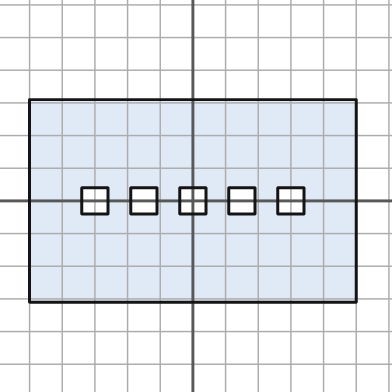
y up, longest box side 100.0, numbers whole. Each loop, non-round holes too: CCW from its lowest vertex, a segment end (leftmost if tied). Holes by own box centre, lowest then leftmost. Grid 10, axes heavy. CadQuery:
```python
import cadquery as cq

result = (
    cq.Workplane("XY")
    .moveTo(-50.0, -31.0)
    .lineTo(50.0, -31.0)
    .lineTo(50.0, 31.0)
    .lineTo(-50.0, 31.0)
    .close()
    .moveTo(-34.0, -4.0)
    .lineTo(-26.0, -4.0)
    .lineTo(-26.0, 4.0)
    .lineTo(-34.0, 4.0)
    .close()
    .moveTo(-19.0, -4.0)
    .lineTo(-11.0, -4.0)
    .lineTo(-11.0, 4.0)
    .lineTo(-19.0, 4.0)
    .close()
    .moveTo(-4.0, -4.0)
    .lineTo(4.0, -4.0)
    .lineTo(4.0, 4.0)
    .lineTo(-4.0, 4.0)
    .close()
    .moveTo(11.0, -4.0)
    .lineTo(19.0, -4.0)
    .lineTo(19.0, 4.0)
    .lineTo(11.0, 4.0)
    .close()
    .moveTo(26.0, -4.0)
    .lineTo(34.0, -4.0)
    .lineTo(34.0, 4.0)
    .lineTo(26.0, 4.0)
    .close()
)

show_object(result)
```